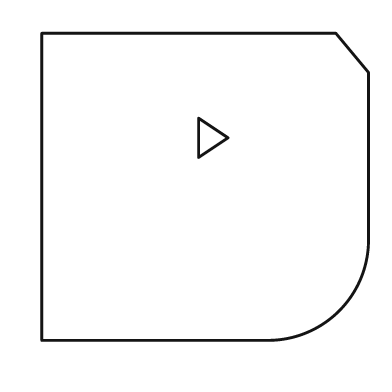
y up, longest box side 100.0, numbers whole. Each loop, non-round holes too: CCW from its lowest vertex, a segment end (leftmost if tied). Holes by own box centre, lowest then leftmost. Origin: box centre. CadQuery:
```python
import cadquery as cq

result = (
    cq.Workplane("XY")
    .moveTo(-50.0, -47.0)
    .lineTo(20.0, -47.0)
    .threePointArc((41.0, -38.0), (50.0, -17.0))
    .lineTo(50.0, 35.0)
    .lineTo(40.0, 47.0)
    .lineTo(-50.0, 47.0)
    .close()
    .moveTo(-2.0, 9.0)
    .lineTo(7.0, 15.0)
    .lineTo(-2.0, 21.0)
    .close()
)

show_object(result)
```